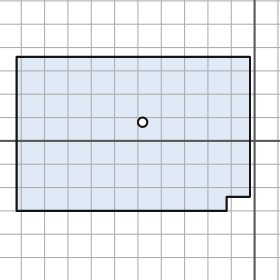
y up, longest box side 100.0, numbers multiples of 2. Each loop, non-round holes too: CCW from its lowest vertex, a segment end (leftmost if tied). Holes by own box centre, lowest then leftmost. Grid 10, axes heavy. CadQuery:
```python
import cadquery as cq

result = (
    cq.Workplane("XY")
    .moveTo(-102.0, -30.0)
    .lineTo(-12.0, -30.0)
    .lineTo(-12.0, -24.0)
    .lineTo(-2.0, -24.0)
    .lineTo(-2.0, 36.0)
    .lineTo(-102.0, 36.0)
    .close()
    .moveTo(-48.0, 8.0)
    .circle(2.0)
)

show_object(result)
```